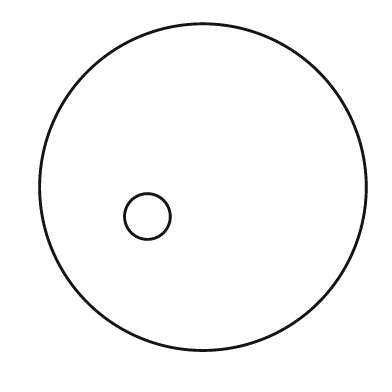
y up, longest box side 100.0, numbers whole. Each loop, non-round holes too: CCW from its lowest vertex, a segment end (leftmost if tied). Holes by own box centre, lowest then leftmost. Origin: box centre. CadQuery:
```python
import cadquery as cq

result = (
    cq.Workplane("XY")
    .moveTo(0.0, 0.0)
    .circle(50.0)
    .moveTo(-17.0, -9.0)
    .circle(7.0)
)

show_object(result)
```